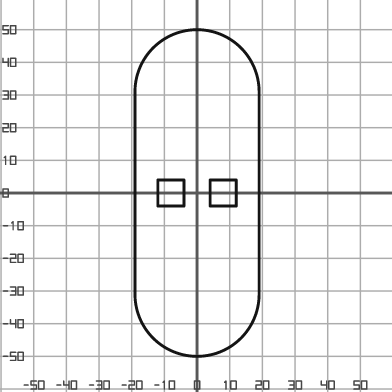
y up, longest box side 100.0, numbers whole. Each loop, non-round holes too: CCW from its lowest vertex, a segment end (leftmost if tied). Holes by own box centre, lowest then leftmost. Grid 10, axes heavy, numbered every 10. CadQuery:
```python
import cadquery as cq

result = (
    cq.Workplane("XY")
    .moveTo(-19.0, -31.0)
    .threePointArc((0.0, -50.0), (19.0, -31.0))
    .lineTo(19.0, 31.0)
    .threePointArc((0.0, 50.0), (-19.0, 31.0))
    .close()
    .moveTo(-12.0, -4.0)
    .lineTo(-4.0, -4.0)
    .lineTo(-4.0, 4.0)
    .lineTo(-12.0, 4.0)
    .close()
    .moveTo(4.0, -4.0)
    .lineTo(12.0, -4.0)
    .lineTo(12.0, 4.0)
    .lineTo(4.0, 4.0)
    .close()
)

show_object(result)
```